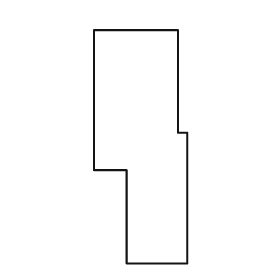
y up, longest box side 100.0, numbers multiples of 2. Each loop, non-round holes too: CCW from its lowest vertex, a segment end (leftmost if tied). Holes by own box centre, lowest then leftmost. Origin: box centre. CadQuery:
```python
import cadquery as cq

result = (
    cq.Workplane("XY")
    .moveTo(-6.0, -50.0)
    .lineTo(20.0, -50.0)
    .lineTo(20.0, 6.0)
    .lineTo(16.0, 6.0)
    .lineTo(16.0, 50.0)
    .lineTo(-20.0, 50.0)
    .lineTo(-20.0, -10.0)
    .lineTo(-6.0, -10.0)
    .close()
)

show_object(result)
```